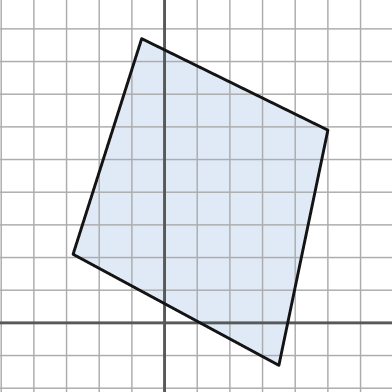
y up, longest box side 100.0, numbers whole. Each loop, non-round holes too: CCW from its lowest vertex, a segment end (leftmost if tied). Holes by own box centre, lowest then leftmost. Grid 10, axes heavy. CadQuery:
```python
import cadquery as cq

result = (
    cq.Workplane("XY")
    .moveTo(35.0, -13.0)
    .lineTo(50.0, 59.0)
    .lineTo(-7.0, 87.0)
    .lineTo(-28.0, 21.0)
    .close()
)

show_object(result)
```